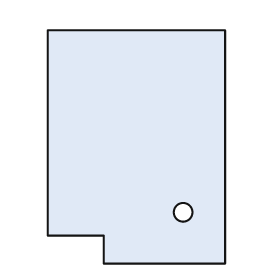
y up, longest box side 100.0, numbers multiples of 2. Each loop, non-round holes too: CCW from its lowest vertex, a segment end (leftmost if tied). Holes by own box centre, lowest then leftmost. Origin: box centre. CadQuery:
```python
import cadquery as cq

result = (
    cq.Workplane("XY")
    .moveTo(-14.0, -50.0)
    .lineTo(38.0, -50.0)
    .lineTo(38.0, 50.0)
    .lineTo(-38.0, 50.0)
    .lineTo(-38.0, -38.0)
    .lineTo(-14.0, -38.0)
    .close()
    .moveTo(20.0, -28.0)
    .circle(4.0)
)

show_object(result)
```